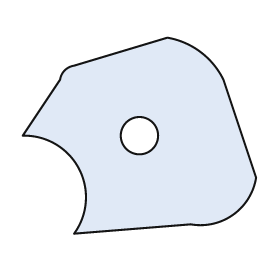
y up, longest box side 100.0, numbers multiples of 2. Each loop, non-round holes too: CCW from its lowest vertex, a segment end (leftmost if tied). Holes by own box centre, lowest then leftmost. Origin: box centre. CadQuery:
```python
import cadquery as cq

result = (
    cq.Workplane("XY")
    .moveTo(-28.0, -42.0)
    .lineTo(22.0, -38.0)
    .threePointArc((40.0, -34.0), (50.0, -18.0))
    .lineTo(36.0, 24.0)
    .threePointArc((26.0, 36.0), (12.0, 42.0))
    .lineTo(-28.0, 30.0)
    .threePointArc((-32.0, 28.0), (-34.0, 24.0))
    .lineTo(-50.0, 0.0)
    .threePointArc((-26.0, -14.0), (-28.0, -42.0))
    .close()
    .moveTo(0.0, 0.0)
    .circle(8.0)
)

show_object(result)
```